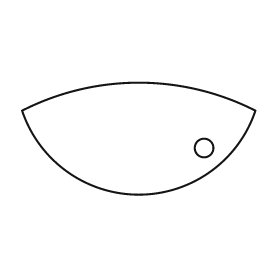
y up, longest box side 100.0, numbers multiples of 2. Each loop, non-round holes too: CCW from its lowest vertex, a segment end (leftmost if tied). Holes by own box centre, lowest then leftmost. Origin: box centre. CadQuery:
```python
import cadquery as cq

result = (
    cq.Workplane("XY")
    .moveTo(-50.0, 12.0)
    .threePointArc((0.0, -24.0), (50.0, 12.0))
    .threePointArc((0.0, 24.0), (-50.0, 12.0))
    .close()
    .moveTo(28.0, -4.0)
    .circle(4.0)
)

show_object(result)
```